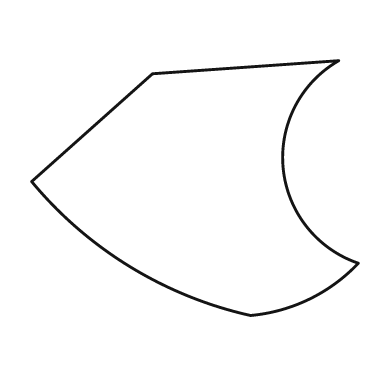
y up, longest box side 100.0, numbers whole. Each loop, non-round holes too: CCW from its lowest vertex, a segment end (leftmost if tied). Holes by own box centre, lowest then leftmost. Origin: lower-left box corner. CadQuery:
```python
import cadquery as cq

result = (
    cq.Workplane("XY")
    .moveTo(67.0, 0.0)
    .threePointArc((85.0, 5.0), (100.0, 16.0))
    .threePointArc((77.0, 45.0), (94.0, 78.0))
    .lineTo(37.0, 74.0)
    .lineTo(0.0, 41.0)
    .threePointArc((30.0, 15.0), (67.0, 0.0))
    .close()
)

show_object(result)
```